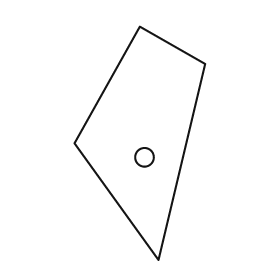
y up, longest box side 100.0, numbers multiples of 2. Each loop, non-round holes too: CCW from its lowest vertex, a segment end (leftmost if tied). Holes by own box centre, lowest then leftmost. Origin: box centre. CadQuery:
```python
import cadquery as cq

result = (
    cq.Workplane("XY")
    .moveTo(8.0, -50.0)
    .lineTo(28.0, 34.0)
    .lineTo(0.0, 50.0)
    .lineTo(-28.0, 0.0)
    .close()
    .moveTo(2.0, -6.0)
    .circle(4.0)
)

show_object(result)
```